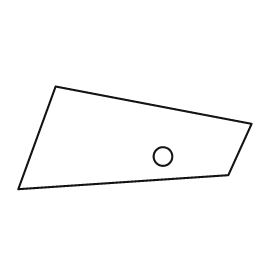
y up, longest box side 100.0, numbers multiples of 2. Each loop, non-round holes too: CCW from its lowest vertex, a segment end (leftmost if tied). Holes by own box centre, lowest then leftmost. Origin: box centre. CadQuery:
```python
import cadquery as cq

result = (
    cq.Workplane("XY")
    .moveTo(-50.0, -22.0)
    .lineTo(40.0, -16.0)
    .lineTo(50.0, 6.0)
    .lineTo(-34.0, 22.0)
    .close()
    .moveTo(12.0, -8.0)
    .circle(4.0)
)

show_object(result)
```